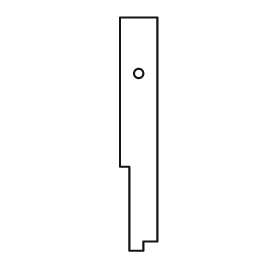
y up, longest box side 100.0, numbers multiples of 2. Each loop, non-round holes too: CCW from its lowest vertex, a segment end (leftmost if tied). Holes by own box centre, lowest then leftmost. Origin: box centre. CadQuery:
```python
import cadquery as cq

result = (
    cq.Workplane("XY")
    .moveTo(-4.0, -50.0)
    .lineTo(2.0, -50.0)
    .lineTo(2.0, -46.0)
    .lineTo(8.0, -46.0)
    .lineTo(8.0, 50.0)
    .lineTo(-8.0, 50.0)
    .lineTo(-8.0, -14.0)
    .lineTo(-4.0, -14.0)
    .close()
    .moveTo(0.0, 26.0)
    .circle(2.0)
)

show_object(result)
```